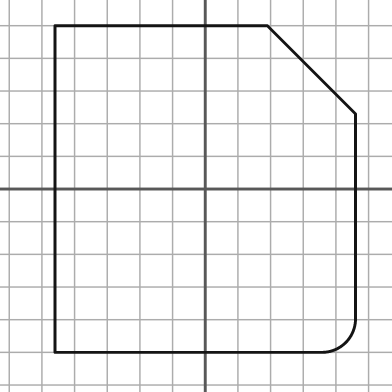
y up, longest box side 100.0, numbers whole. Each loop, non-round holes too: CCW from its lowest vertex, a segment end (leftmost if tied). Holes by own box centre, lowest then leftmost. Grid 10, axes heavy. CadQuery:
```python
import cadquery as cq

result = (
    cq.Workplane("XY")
    .moveTo(-46.0, -50.0)
    .lineTo(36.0, -50.0)
    .threePointArc((43.0, -47.0), (46.0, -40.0))
    .lineTo(46.0, 23.0)
    .lineTo(19.0, 50.0)
    .lineTo(-46.0, 50.0)
    .close()
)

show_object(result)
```